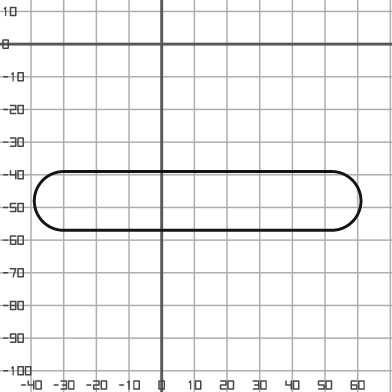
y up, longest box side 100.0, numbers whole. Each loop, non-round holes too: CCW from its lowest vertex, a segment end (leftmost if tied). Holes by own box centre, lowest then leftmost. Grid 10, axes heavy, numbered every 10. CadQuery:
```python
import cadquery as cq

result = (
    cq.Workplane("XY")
    .moveTo(-30.0, -57.0)
    .lineTo(52.0, -57.0)
    .threePointArc((61.0, -48.0), (52.0, -39.0))
    .lineTo(-30.0, -39.0)
    .threePointArc((-39.0, -48.0), (-30.0, -57.0))
    .close()
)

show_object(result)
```